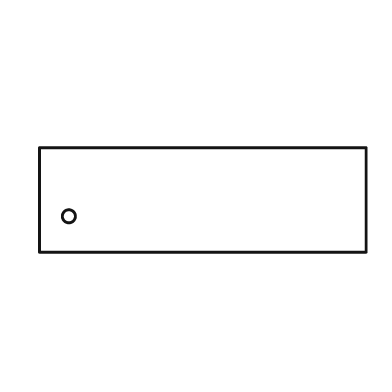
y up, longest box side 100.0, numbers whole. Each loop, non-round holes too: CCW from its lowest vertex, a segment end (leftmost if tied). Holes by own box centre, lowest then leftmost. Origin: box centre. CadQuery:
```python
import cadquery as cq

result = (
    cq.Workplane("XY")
    .moveTo(-50.0, -16.0)
    .lineTo(50.0, -16.0)
    .lineTo(50.0, 16.0)
    .lineTo(-50.0, 16.0)
    .close()
    .moveTo(-41.0, -5.0)
    .circle(2.0)
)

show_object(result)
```